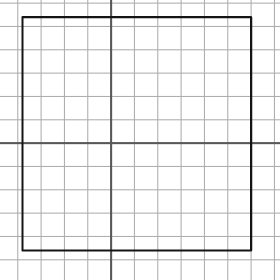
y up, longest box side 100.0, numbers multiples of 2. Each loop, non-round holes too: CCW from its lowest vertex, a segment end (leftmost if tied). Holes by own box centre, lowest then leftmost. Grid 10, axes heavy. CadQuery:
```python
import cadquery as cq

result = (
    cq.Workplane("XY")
    .moveTo(-38.0, -46.0)
    .lineTo(60.0, -46.0)
    .lineTo(60.0, 54.0)
    .lineTo(-38.0, 54.0)
    .close()
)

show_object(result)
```